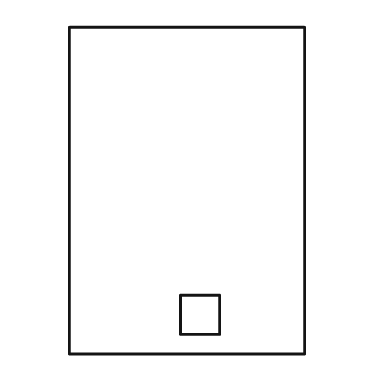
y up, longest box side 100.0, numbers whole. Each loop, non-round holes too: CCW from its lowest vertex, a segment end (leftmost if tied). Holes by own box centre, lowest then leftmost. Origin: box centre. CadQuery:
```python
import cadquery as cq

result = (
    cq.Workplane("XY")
    .moveTo(-36.0, -50.0)
    .lineTo(36.0, -50.0)
    .lineTo(36.0, 50.0)
    .lineTo(-36.0, 50.0)
    .close()
    .moveTo(-2.0, -44.0)
    .lineTo(10.0, -44.0)
    .lineTo(10.0, -32.0)
    .lineTo(-2.0, -32.0)
    .close()
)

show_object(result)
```